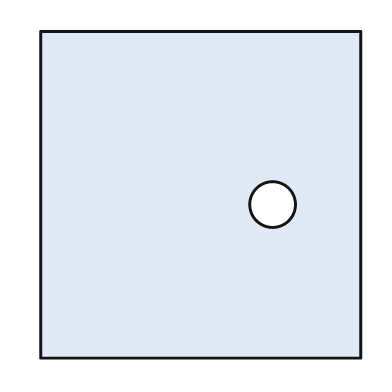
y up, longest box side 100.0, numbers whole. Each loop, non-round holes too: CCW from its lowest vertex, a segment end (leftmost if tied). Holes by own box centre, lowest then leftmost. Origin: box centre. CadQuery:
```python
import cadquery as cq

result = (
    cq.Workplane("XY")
    .moveTo(-49.0, -50.0)
    .lineTo(49.0, -50.0)
    .lineTo(49.0, 50.0)
    .lineTo(-49.0, 50.0)
    .close()
    .moveTo(22.0, -3.0)
    .circle(7.0)
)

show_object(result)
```